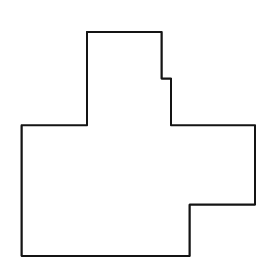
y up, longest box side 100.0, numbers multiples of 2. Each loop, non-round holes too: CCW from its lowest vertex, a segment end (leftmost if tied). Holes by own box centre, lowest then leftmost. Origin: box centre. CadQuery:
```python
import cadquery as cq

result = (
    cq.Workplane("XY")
    .moveTo(-50.0, -48.0)
    .lineTo(22.0, -48.0)
    .lineTo(22.0, -26.0)
    .lineTo(50.0, -26.0)
    .lineTo(50.0, 8.0)
    .lineTo(14.0, 8.0)
    .lineTo(14.0, 28.0)
    .lineTo(10.0, 28.0)
    .lineTo(10.0, 48.0)
    .lineTo(-22.0, 48.0)
    .lineTo(-22.0, 8.0)
    .lineTo(-50.0, 8.0)
    .close()
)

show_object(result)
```